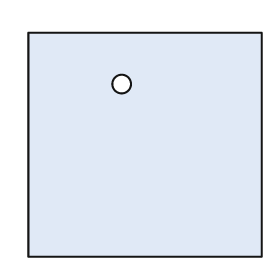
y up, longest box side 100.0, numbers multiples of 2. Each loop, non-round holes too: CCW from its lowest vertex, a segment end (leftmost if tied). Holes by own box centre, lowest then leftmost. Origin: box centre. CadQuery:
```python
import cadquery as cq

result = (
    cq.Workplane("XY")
    .moveTo(-50.0, -48.0)
    .lineTo(50.0, -48.0)
    .lineTo(50.0, 48.0)
    .lineTo(-50.0, 48.0)
    .close()
    .moveTo(-10.0, 26.0)
    .circle(4.0)
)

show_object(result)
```